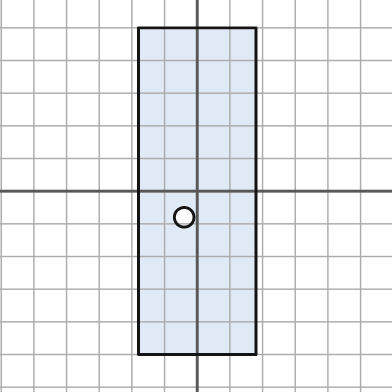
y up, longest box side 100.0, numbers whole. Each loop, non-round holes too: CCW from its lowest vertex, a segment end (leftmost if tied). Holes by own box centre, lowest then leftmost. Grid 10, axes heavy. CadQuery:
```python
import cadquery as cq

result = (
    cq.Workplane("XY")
    .moveTo(-18.0, -50.0)
    .lineTo(18.0, -50.0)
    .lineTo(18.0, 50.0)
    .lineTo(-18.0, 50.0)
    .close()
    .moveTo(-4.0, -8.0)
    .circle(3.0)
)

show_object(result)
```